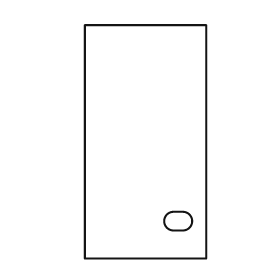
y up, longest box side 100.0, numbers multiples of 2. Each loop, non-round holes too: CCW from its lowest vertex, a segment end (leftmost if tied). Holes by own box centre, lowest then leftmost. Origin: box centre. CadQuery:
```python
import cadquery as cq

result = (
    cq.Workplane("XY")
    .moveTo(-26.0, -50.0)
    .lineTo(26.0, -50.0)
    .lineTo(26.0, 50.0)
    .lineTo(-26.0, 50.0)
    .close()
    .moveTo(12.0, -38.0)
    .lineTo(16.0, -38.0)
    .threePointArc((20.0, -34.0), (16.0, -30.0))
    .lineTo(12.0, -30.0)
    .threePointArc((8.0, -34.0), (12.0, -38.0))
    .close()
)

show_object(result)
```